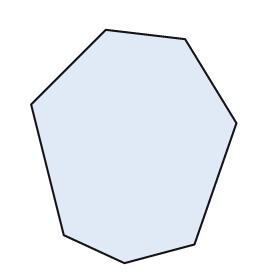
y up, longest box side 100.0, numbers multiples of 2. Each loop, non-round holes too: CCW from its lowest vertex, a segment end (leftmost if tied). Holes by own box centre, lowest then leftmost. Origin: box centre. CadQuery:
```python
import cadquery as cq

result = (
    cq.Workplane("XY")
    .moveTo(-4.0, -50.0)
    .lineTo(26.0, -42.0)
    .lineTo(44.0, 10.0)
    .lineTo(22.0, 46.0)
    .lineTo(-12.0, 50.0)
    .lineTo(-44.0, 18.0)
    .lineTo(-30.0, -38.0)
    .close()
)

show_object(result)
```